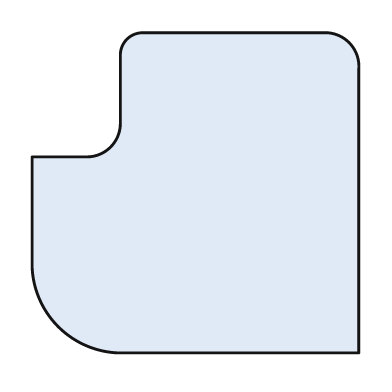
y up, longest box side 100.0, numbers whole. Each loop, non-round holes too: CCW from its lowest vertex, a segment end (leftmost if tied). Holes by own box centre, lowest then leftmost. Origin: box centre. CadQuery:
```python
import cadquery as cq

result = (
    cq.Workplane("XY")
    .moveTo(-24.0, -49.0)
    .lineTo(50.0, -49.0)
    .lineTo(50.0, 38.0)
    .threePointArc((47.0, 46.0), (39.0, 49.0))
    .lineTo(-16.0, 49.0)
    .threePointArc((-21.0, 47.0), (-23.0, 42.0))
    .lineTo(-23.0, 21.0)
    .threePointArc((-26.0, 14.0), (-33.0, 11.0))
    .lineTo(-50.0, 11.0)
    .lineTo(-50.0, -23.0)
    .threePointArc((-42.0, -41.0), (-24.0, -49.0))
    .close()
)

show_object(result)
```